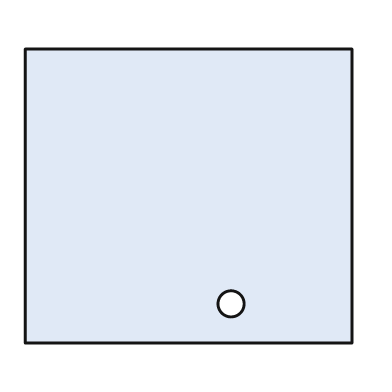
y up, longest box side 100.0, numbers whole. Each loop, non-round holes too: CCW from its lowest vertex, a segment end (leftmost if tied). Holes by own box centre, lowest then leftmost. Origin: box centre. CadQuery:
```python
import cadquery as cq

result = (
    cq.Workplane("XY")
    .moveTo(-50.0, -45.0)
    .lineTo(50.0, -45.0)
    .lineTo(50.0, 45.0)
    .lineTo(-50.0, 45.0)
    .close()
    .moveTo(13.0, -33.0)
    .circle(4.0)
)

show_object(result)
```